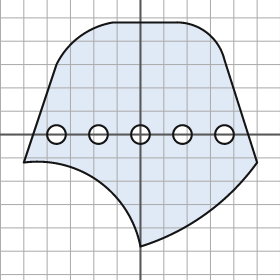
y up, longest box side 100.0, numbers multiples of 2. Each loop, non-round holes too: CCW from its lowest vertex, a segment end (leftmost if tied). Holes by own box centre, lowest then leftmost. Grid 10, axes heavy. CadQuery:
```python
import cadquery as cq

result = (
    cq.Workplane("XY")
    .moveTo(0.0, -48.0)
    .threePointArc((28.0, -34.0), (50.0, -12.0))
    .lineTo(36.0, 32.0)
    .threePointArc((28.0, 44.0), (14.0, 48.0))
    .lineTo(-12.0, 48.0)
    .threePointArc((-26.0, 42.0), (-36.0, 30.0))
    .lineTo(-50.0, -12.0)
    .threePointArc((-18.0, -20.0), (0.0, -48.0))
    .close()
    .moveTo(-36.0, 0.0)
    .circle(4.0)
    .moveTo(-18.0, 0.0)
    .circle(4.0)
    .moveTo(0.0, 0.0)
    .circle(4.0)
    .moveTo(18.0, 0.0)
    .circle(4.0)
    .moveTo(36.0, 0.0)
    .circle(4.0)
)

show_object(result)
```